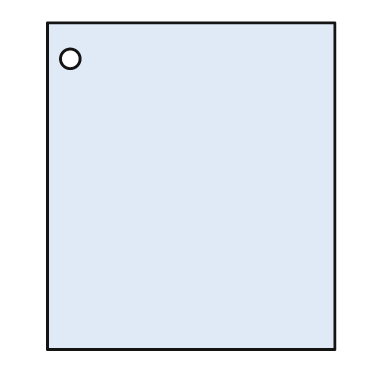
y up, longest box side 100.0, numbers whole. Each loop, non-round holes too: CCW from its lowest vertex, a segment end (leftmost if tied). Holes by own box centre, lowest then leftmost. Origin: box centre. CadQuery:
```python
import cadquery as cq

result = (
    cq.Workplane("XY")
    .moveTo(-44.0, -50.0)
    .lineTo(44.0, -50.0)
    .lineTo(44.0, 50.0)
    .lineTo(-44.0, 50.0)
    .close()
    .moveTo(-37.0, 39.0)
    .circle(3.0)
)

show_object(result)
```